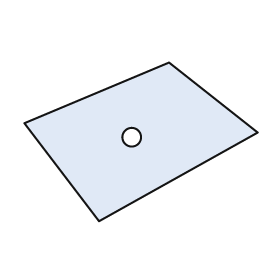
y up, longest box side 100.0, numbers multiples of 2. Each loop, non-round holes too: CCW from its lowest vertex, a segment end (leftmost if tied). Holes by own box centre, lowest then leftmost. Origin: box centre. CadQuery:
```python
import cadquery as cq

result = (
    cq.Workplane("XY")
    .moveTo(-18.0, -34.0)
    .lineTo(50.0, 4.0)
    .lineTo(12.0, 34.0)
    .lineTo(-50.0, 8.0)
    .close()
    .moveTo(-4.0, 2.0)
    .circle(4.0)
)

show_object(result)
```